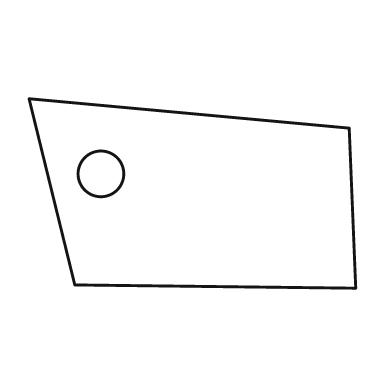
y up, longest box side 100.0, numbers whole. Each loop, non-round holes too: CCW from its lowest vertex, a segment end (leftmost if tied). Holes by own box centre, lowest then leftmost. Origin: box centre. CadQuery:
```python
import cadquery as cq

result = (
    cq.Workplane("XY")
    .moveTo(50.0, -29.0)
    .lineTo(48.0, 20.0)
    .lineTo(-50.0, 29.0)
    .lineTo(-36.0, -28.0)
    .close()
    .moveTo(-28.0, 6.0)
    .circle(7.0)
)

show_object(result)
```